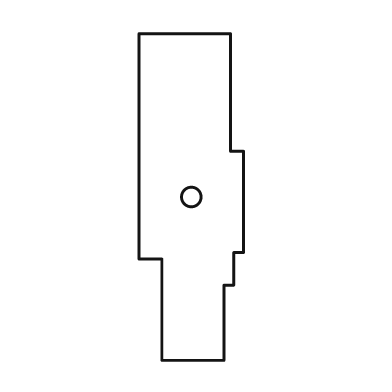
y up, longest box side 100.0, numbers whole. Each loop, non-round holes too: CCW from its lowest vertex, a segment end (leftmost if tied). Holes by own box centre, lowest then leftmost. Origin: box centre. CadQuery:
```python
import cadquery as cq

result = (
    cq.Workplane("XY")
    .moveTo(-9.0, -50.0)
    .lineTo(10.0, -50.0)
    .lineTo(10.0, -27.0)
    .lineTo(13.0, -27.0)
    .lineTo(13.0, -17.0)
    .lineTo(16.0, -17.0)
    .lineTo(16.0, 14.0)
    .lineTo(12.0, 14.0)
    .lineTo(12.0, 50.0)
    .lineTo(-16.0, 50.0)
    .lineTo(-16.0, -19.0)
    .lineTo(-9.0, -19.0)
    .close()
    .moveTo(0.0, 0.0)
    .circle(3.0)
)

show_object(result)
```